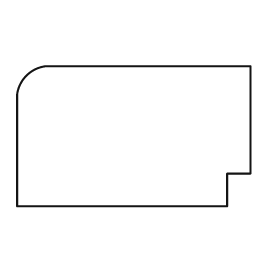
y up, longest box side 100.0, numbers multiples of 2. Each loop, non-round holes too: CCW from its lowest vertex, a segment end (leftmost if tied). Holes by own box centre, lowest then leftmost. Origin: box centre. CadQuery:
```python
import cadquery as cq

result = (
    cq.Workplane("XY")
    .moveTo(-50.0, -30.0)
    .lineTo(40.0, -30.0)
    .lineTo(40.0, -16.0)
    .lineTo(50.0, -16.0)
    .lineTo(50.0, 30.0)
    .lineTo(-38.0, 30.0)
    .threePointArc((-46.0, 26.0), (-50.0, 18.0))
    .close()
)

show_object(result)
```